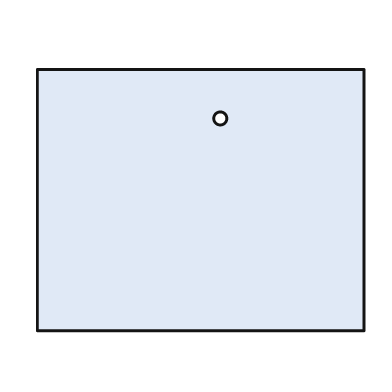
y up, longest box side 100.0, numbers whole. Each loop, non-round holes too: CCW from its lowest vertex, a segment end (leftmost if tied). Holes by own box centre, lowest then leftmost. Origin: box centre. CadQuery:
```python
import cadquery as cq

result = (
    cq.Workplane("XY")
    .moveTo(-50.0, -40.0)
    .lineTo(50.0, -40.0)
    .lineTo(50.0, 40.0)
    .lineTo(-50.0, 40.0)
    .close()
    .moveTo(6.0, 25.0)
    .circle(2.0)
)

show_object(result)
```